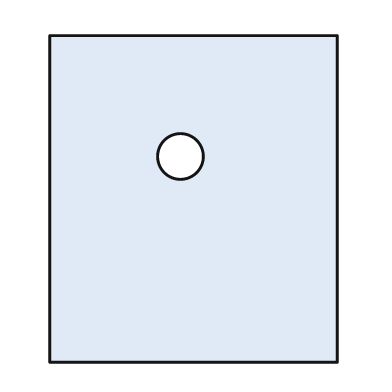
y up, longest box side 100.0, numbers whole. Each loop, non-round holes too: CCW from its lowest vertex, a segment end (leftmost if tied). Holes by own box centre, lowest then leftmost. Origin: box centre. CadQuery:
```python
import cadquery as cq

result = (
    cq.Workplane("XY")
    .moveTo(-44.0, -50.0)
    .lineTo(44.0, -50.0)
    .lineTo(44.0, 50.0)
    .lineTo(-44.0, 50.0)
    .close()
    .moveTo(-4.0, 13.0)
    .circle(7.0)
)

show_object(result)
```